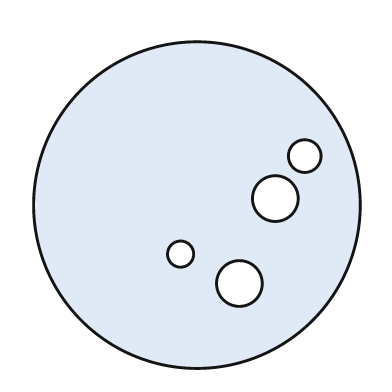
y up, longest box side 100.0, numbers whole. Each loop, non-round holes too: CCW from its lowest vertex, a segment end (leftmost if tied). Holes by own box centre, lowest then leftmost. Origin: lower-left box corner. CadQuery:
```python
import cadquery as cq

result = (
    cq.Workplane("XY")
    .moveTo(50.0, 50.0)
    .circle(50.0)
    .moveTo(63.0, 26.0)
    .circle(7.0)
    .moveTo(45.0, 35.0)
    .circle(4.0)
    .moveTo(74.0, 52.0)
    .circle(7.0)
    .moveTo(83.0, 65.0)
    .circle(5.0)
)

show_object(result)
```